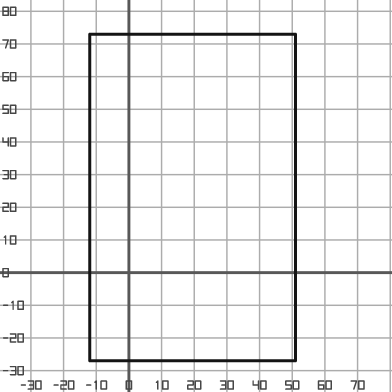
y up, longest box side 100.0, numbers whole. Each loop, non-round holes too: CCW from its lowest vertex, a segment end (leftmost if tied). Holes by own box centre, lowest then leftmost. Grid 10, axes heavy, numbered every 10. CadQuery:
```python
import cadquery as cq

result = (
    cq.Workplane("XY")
    .moveTo(-12.0, -27.0)
    .lineTo(51.0, -27.0)
    .lineTo(51.0, 73.0)
    .lineTo(-12.0, 73.0)
    .close()
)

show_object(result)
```